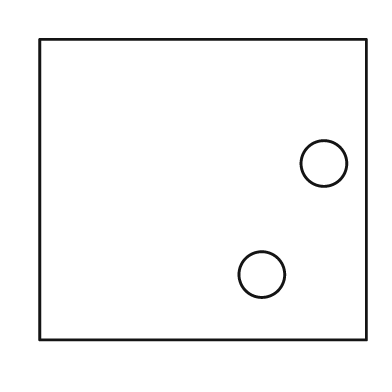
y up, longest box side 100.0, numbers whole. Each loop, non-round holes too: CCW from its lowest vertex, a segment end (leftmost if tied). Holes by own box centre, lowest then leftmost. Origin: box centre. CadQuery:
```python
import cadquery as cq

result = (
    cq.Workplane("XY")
    .moveTo(-50.0, -46.0)
    .lineTo(50.0, -46.0)
    .lineTo(50.0, 46.0)
    .lineTo(-50.0, 46.0)
    .close()
    .moveTo(18.0, -26.0)
    .circle(7.0)
    .moveTo(37.0, 8.0)
    .circle(7.0)
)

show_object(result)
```